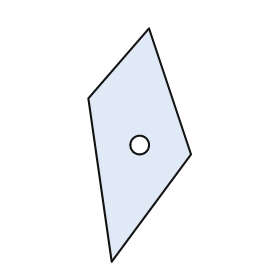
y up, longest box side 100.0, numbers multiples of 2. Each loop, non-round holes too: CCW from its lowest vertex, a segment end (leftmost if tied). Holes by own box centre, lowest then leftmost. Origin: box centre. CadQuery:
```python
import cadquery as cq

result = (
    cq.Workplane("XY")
    .moveTo(-12.0, -50.0)
    .lineTo(22.0, -4.0)
    .lineTo(4.0, 50.0)
    .lineTo(-22.0, 20.0)
    .close()
    .moveTo(0.0, 0.0)
    .circle(4.0)
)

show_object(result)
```